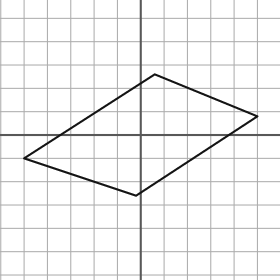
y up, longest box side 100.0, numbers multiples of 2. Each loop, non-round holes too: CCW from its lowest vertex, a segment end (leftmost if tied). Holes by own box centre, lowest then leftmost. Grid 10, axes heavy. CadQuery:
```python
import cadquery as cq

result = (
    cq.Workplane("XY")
    .moveTo(-2.0, -26.0)
    .lineTo(50.0, 8.0)
    .lineTo(6.0, 26.0)
    .lineTo(-50.0, -10.0)
    .close()
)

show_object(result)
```